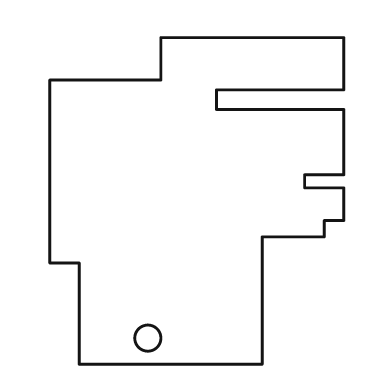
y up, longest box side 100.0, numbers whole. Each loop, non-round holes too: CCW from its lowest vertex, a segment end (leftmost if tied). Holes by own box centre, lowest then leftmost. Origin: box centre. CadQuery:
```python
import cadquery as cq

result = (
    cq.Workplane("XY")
    .moveTo(-36.0, -50.0)
    .lineTo(20.0, -50.0)
    .lineTo(20.0, -11.0)
    .lineTo(39.0, -11.0)
    .lineTo(39.0, -6.0)
    .lineTo(45.0, -6.0)
    .lineTo(45.0, 4.0)
    .lineTo(33.0, 4.0)
    .lineTo(33.0, 8.0)
    .lineTo(45.0, 8.0)
    .lineTo(45.0, 28.0)
    .lineTo(6.0, 28.0)
    .lineTo(6.0, 34.0)
    .lineTo(45.0, 34.0)
    .lineTo(45.0, 50.0)
    .lineTo(-11.0, 50.0)
    .lineTo(-11.0, 37.0)
    .lineTo(-45.0, 37.0)
    .lineTo(-45.0, -19.0)
    .lineTo(-36.0, -19.0)
    .close()
    .moveTo(-15.0, -42.0)
    .circle(4.0)
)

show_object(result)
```